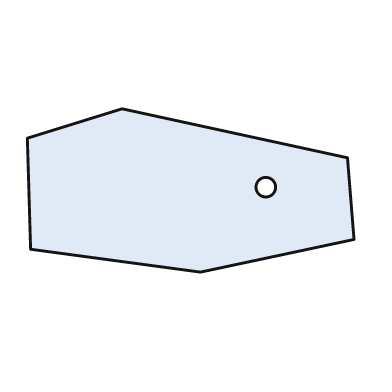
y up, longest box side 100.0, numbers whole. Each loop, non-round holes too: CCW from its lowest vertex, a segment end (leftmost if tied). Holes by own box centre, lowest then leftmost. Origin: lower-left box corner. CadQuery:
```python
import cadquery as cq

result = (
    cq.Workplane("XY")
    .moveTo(53.0, 0.0)
    .lineTo(100.0, 10.0)
    .lineTo(98.0, 35.0)
    .lineTo(29.0, 50.0)
    .lineTo(0.0, 41.0)
    .lineTo(1.0, 7.0)
    .close()
    .moveTo(73.0, 26.0)
    .circle(3.0)
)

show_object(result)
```